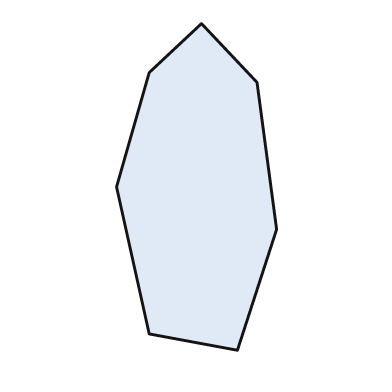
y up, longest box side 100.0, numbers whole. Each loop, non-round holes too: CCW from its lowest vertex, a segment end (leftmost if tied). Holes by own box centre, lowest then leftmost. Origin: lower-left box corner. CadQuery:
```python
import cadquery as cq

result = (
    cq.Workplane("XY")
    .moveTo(37.0, 0.0)
    .lineTo(49.0, 37.0)
    .lineTo(43.0, 82.0)
    .lineTo(26.0, 100.0)
    .lineTo(10.0, 85.0)
    .lineTo(0.0, 50.0)
    .lineTo(10.0, 5.0)
    .close()
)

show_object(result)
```